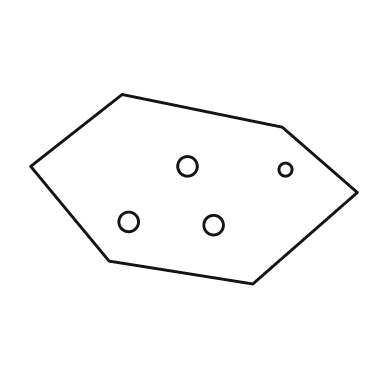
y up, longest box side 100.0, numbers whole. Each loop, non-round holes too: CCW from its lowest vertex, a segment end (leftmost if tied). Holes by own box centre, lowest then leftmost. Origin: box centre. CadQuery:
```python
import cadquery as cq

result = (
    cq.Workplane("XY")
    .moveTo(18.0, -29.0)
    .lineTo(50.0, -1.0)
    .lineTo(27.0, 19.0)
    .lineTo(-22.0, 29.0)
    .lineTo(-50.0, 7.0)
    .lineTo(-26.0, -22.0)
    .close()
    .moveTo(6.0, -11.0)
    .circle(3.0)
    .moveTo(-20.0, -10.0)
    .circle(3.0)
    .moveTo(28.0, 6.0)
    .circle(2.0)
    .moveTo(-2.0, 7.0)
    .circle(3.0)
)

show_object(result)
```